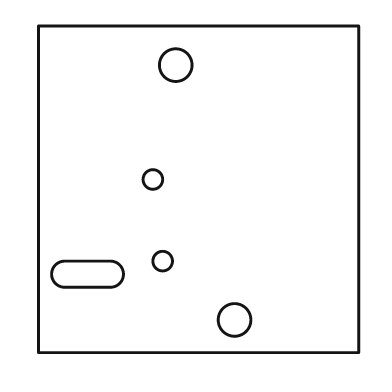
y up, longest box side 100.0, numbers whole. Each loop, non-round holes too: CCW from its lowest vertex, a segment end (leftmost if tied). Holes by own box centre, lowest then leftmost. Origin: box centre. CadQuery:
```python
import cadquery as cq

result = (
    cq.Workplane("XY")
    .moveTo(-49.0, -50.0)
    .lineTo(49.0, -50.0)
    .lineTo(49.0, 50.0)
    .lineTo(-49.0, 50.0)
    .close()
    .moveTo(11.0, -40.0)
    .circle(5.0)
    .moveTo(-41.0, -30.0)
    .lineTo(-27.0, -30.0)
    .threePointArc((-23.0, -26.0), (-27.0, -22.0))
    .lineTo(-41.0, -22.0)
    .threePointArc((-45.0, -26.0), (-41.0, -30.0))
    .close()
    .moveTo(-11.0, -22.0)
    .circle(3.0)
    .moveTo(-14.0, 3.0)
    .circle(3.0)
    .moveTo(-7.0, 38.0)
    .circle(5.0)
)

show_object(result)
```